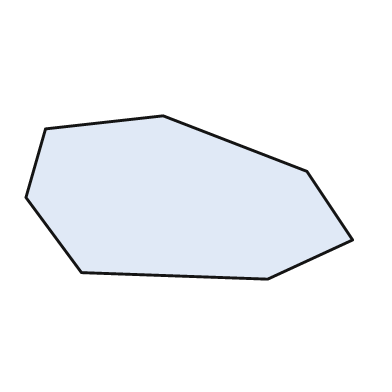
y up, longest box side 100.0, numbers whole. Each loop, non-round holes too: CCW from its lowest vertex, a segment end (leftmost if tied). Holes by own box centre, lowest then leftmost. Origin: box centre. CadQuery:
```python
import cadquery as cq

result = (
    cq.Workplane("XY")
    .moveTo(24.0, -25.0)
    .lineTo(50.0, -13.0)
    .lineTo(36.0, 8.0)
    .lineTo(-8.0, 25.0)
    .lineTo(-44.0, 21.0)
    .lineTo(-50.0, 0.0)
    .lineTo(-33.0, -23.0)
    .close()
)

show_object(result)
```